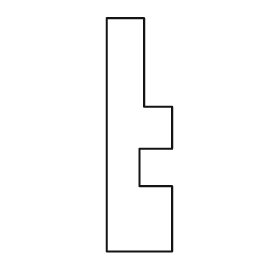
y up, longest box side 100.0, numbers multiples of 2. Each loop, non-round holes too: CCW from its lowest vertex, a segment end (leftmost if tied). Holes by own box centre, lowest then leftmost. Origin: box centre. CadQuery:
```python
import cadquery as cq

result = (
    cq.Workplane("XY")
    .moveTo(-14.0, -50.0)
    .lineTo(14.0, -50.0)
    .lineTo(14.0, -22.0)
    .lineTo(0.0, -22.0)
    .lineTo(0.0, -6.0)
    .lineTo(14.0, -6.0)
    .lineTo(14.0, 12.0)
    .lineTo(2.0, 12.0)
    .lineTo(2.0, 50.0)
    .lineTo(-14.0, 50.0)
    .close()
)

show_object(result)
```